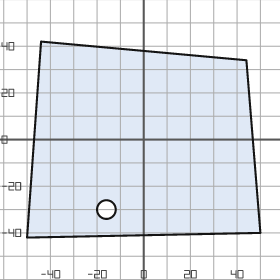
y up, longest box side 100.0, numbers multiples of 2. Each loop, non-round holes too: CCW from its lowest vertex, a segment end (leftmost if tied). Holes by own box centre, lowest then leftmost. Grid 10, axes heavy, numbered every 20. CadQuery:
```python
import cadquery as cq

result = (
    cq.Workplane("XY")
    .moveTo(-50.0, -42.0)
    .lineTo(50.0, -40.0)
    .lineTo(44.0, 34.0)
    .lineTo(-44.0, 42.0)
    .close()
    .moveTo(-16.0, -30.0)
    .circle(4.0)
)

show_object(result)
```